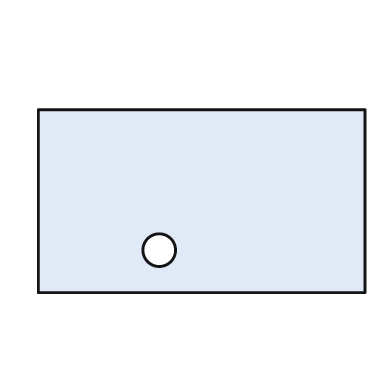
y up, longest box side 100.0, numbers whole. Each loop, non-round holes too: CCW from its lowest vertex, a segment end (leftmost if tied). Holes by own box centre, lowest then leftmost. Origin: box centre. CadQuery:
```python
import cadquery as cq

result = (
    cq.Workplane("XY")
    .moveTo(-50.0, -28.0)
    .lineTo(50.0, -28.0)
    .lineTo(50.0, 28.0)
    .lineTo(-50.0, 28.0)
    .close()
    .moveTo(-13.0, -15.0)
    .circle(5.0)
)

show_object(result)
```